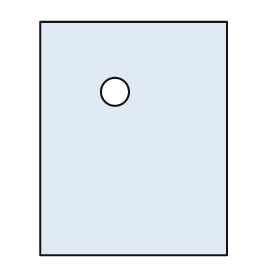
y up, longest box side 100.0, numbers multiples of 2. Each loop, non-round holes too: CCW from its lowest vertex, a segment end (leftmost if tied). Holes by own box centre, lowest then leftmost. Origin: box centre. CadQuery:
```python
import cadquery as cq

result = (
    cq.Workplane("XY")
    .moveTo(-40.0, -50.0)
    .lineTo(40.0, -50.0)
    .lineTo(40.0, 50.0)
    .lineTo(-40.0, 50.0)
    .close()
    .moveTo(-8.0, 20.0)
    .circle(6.0)
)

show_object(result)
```